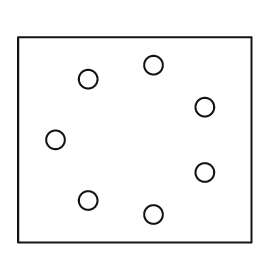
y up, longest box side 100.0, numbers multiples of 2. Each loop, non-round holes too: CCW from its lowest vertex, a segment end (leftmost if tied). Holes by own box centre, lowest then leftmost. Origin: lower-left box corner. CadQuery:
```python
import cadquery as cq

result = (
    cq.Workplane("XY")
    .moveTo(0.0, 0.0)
    .lineTo(100.0, 0.0)
    .lineTo(100.0, 88.0)
    .lineTo(0.0, 88.0)
    .close()
    .moveTo(58.0, 12.0)
    .circle(4.0)
    .moveTo(30.0, 18.0)
    .circle(4.0)
    .moveTo(80.0, 30.0)
    .circle(4.0)
    .moveTo(16.0, 44.0)
    .circle(4.0)
    .moveTo(80.0, 58.0)
    .circle(4.0)
    .moveTo(30.0, 70.0)
    .circle(4.0)
    .moveTo(58.0, 76.0)
    .circle(4.0)
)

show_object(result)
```